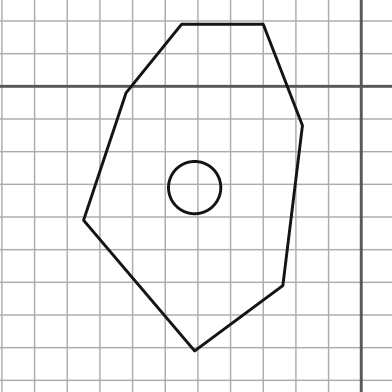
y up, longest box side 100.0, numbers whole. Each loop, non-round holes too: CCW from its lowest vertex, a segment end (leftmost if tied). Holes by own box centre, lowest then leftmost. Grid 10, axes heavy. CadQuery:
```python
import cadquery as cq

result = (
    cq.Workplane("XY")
    .moveTo(-51.0, -81.0)
    .lineTo(-24.0, -61.0)
    .lineTo(-18.0, -12.0)
    .lineTo(-30.0, 19.0)
    .lineTo(-55.0, 19.0)
    .lineTo(-72.0, -2.0)
    .lineTo(-85.0, -41.0)
    .close()
    .moveTo(-51.0, -31.0)
    .circle(8.0)
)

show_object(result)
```